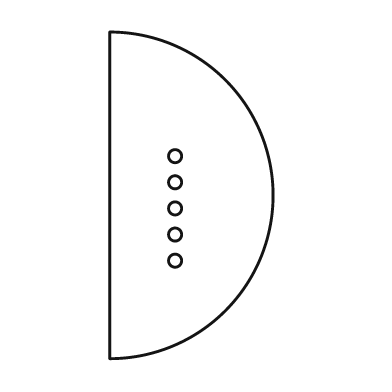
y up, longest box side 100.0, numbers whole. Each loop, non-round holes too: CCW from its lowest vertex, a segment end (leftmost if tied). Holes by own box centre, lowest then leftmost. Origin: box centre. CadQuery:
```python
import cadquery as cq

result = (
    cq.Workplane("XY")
    .moveTo(-25.0, -50.0)
    .threePointArc((25.0, 0.0), (-25.0, 50.0))
    .close()
    .moveTo(-5.0, -20.0)
    .circle(2.0)
    .moveTo(-5.0, -12.0)
    .circle(2.0)
    .moveTo(-5.0, -4.0)
    .circle(2.0)
    .moveTo(-5.0, 4.0)
    .circle(2.0)
    .moveTo(-5.0, 12.0)
    .circle(2.0)
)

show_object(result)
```